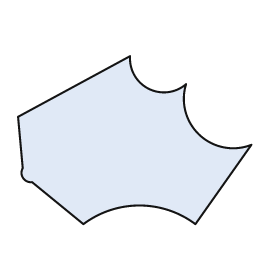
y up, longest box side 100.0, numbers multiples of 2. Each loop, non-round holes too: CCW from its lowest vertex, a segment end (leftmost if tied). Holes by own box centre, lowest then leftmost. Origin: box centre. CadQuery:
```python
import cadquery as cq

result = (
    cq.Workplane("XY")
    .moveTo(-22.0, -36.0)
    .threePointArc((2.0, -28.0), (26.0, -36.0))
    .lineTo(50.0, -2.0)
    .threePointArc((28.0, 2.0), (22.0, 24.0))
    .threePointArc((6.0, 22.0), (-2.0, 36.0))
    .lineTo(-50.0, 10.0)
    .lineTo(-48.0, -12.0)
    .threePointArc((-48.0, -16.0), (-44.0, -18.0))
    .close()
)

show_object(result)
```